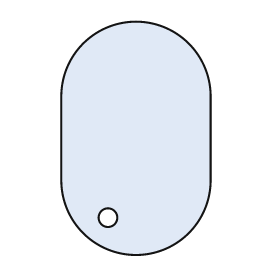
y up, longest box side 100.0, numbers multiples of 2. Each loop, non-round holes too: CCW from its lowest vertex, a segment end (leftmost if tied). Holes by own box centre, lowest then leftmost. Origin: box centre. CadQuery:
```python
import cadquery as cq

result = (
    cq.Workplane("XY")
    .moveTo(-32.0, -18.0)
    .threePointArc((0.0, -50.0), (32.0, -18.0))
    .lineTo(32.0, 18.0)
    .threePointArc((0.0, 50.0), (-32.0, 18.0))
    .close()
    .moveTo(-12.0, -34.0)
    .circle(4.0)
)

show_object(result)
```